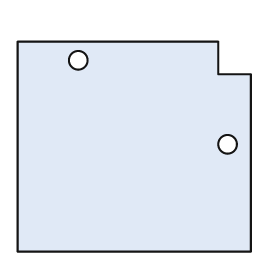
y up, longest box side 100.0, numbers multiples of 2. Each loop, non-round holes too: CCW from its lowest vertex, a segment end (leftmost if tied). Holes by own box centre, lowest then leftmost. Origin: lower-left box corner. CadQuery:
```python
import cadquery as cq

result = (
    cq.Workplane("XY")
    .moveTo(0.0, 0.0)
    .lineTo(100.0, 0.0)
    .lineTo(100.0, 76.0)
    .lineTo(86.0, 76.0)
    .lineTo(86.0, 90.0)
    .lineTo(0.0, 90.0)
    .close()
    .moveTo(90.0, 46.0)
    .circle(4.0)
    .moveTo(26.0, 82.0)
    .circle(4.0)
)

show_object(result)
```